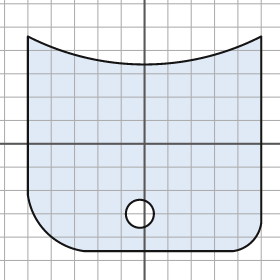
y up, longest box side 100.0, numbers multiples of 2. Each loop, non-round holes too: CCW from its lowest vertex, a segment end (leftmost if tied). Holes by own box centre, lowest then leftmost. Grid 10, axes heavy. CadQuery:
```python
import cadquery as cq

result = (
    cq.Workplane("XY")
    .moveTo(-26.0, -46.0)
    .lineTo(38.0, -46.0)
    .threePointArc((46.0, -42.0), (50.0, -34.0))
    .lineTo(50.0, 46.0)
    .threePointArc((0.0, 34.0), (-50.0, 46.0))
    .lineTo(-50.0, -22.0)
    .threePointArc((-42.0, -38.0), (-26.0, -46.0))
    .close()
    .moveTo(-2.0, -30.0)
    .circle(6.0)
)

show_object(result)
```